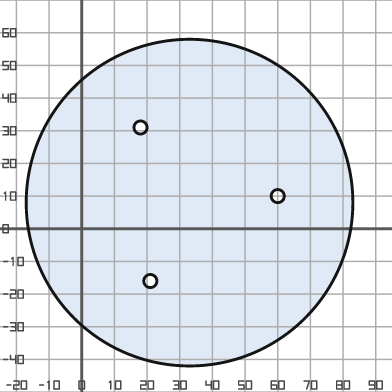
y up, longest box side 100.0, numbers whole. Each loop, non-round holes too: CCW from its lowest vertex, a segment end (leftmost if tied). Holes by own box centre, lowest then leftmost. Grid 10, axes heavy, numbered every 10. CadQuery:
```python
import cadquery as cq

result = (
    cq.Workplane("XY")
    .moveTo(33.0, 8.0)
    .circle(50.0)
    .moveTo(21.0, -16.0)
    .circle(2.0)
    .moveTo(60.0, 10.0)
    .circle(2.0)
    .moveTo(18.0, 31.0)
    .circle(2.0)
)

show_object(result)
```